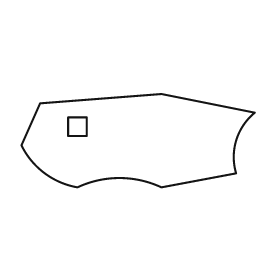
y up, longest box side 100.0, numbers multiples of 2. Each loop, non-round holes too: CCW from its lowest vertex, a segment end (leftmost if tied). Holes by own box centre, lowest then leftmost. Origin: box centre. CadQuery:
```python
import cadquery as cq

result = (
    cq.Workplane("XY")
    .moveTo(-26.0, -20.0)
    .threePointArc((-8.0, -16.0), (10.0, -20.0))
    .lineTo(42.0, -14.0)
    .threePointArc((42.0, 0.0), (50.0, 12.0))
    .lineTo(10.0, 20.0)
    .lineTo(-42.0, 16.0)
    .lineTo(-50.0, -2.0)
    .threePointArc((-40.0, -14.0), (-26.0, -20.0))
    .close()
    .moveTo(-30.0, 2.0)
    .lineTo(-22.0, 2.0)
    .lineTo(-22.0, 10.0)
    .lineTo(-30.0, 10.0)
    .close()
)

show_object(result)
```